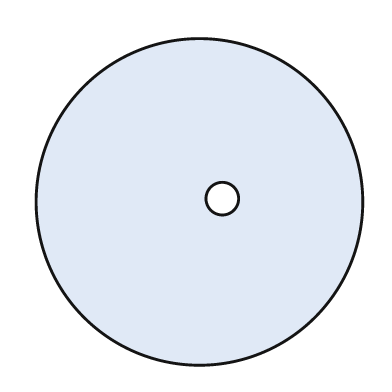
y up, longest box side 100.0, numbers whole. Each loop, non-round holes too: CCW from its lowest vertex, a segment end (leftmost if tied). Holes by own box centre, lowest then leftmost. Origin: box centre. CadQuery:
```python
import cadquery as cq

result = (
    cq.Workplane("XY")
    .moveTo(0.0, 0.0)
    .circle(50.0)
    .moveTo(7.0, 1.0)
    .circle(5.0)
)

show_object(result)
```